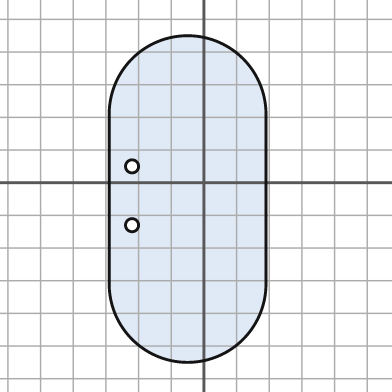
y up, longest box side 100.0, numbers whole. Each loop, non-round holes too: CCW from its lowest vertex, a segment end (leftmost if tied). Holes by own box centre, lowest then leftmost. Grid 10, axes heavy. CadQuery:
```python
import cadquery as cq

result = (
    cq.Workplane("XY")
    .moveTo(-29.0, -31.0)
    .threePointArc((-5.0, -55.0), (19.0, -31.0))
    .lineTo(19.0, 21.0)
    .threePointArc((-5.0, 45.0), (-29.0, 21.0))
    .close()
    .moveTo(-22.0, -13.0)
    .circle(2.0)
    .moveTo(-22.0, 5.0)
    .circle(2.0)
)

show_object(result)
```